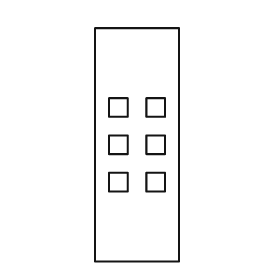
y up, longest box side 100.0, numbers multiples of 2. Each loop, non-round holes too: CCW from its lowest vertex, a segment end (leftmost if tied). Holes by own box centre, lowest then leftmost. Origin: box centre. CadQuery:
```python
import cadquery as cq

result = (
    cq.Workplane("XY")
    .moveTo(-18.0, -50.0)
    .lineTo(18.0, -50.0)
    .lineTo(18.0, 50.0)
    .lineTo(-18.0, 50.0)
    .close()
    .moveTo(-12.0, -20.0)
    .lineTo(-4.0, -20.0)
    .lineTo(-4.0, -12.0)
    .lineTo(-12.0, -12.0)
    .close()
    .moveTo(4.0, -20.0)
    .lineTo(12.0, -20.0)
    .lineTo(12.0, -12.0)
    .lineTo(4.0, -12.0)
    .close()
    .moveTo(-12.0, -4.0)
    .lineTo(-4.0, -4.0)
    .lineTo(-4.0, 4.0)
    .lineTo(-12.0, 4.0)
    .close()
    .moveTo(4.0, -4.0)
    .lineTo(12.0, -4.0)
    .lineTo(12.0, 4.0)
    .lineTo(4.0, 4.0)
    .close()
    .moveTo(-12.0, 12.0)
    .lineTo(-4.0, 12.0)
    .lineTo(-4.0, 20.0)
    .lineTo(-12.0, 20.0)
    .close()
    .moveTo(4.0, 12.0)
    .lineTo(12.0, 12.0)
    .lineTo(12.0, 20.0)
    .lineTo(4.0, 20.0)
    .close()
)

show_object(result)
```